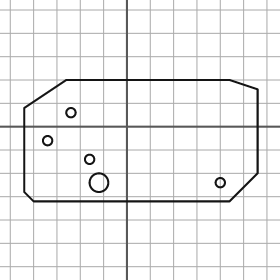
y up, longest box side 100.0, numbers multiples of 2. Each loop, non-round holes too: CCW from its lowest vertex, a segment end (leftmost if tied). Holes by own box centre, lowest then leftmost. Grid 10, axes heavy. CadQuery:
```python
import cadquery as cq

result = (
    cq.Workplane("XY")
    .moveTo(-40.0, -32.0)
    .lineTo(44.0, -32.0)
    .lineTo(56.0, -20.0)
    .lineTo(56.0, 16.0)
    .lineTo(44.0, 20.0)
    .lineTo(-26.0, 20.0)
    .lineTo(-44.0, 8.0)
    .lineTo(-44.0, -28.0)
    .close()
    .moveTo(-12.0, -24.0)
    .circle(4.0)
    .moveTo(40.0, -24.0)
    .circle(2.0)
    .moveTo(-16.0, -14.0)
    .circle(2.0)
    .moveTo(-34.0, -6.0)
    .circle(2.0)
    .moveTo(-24.0, 6.0)
    .circle(2.0)
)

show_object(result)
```